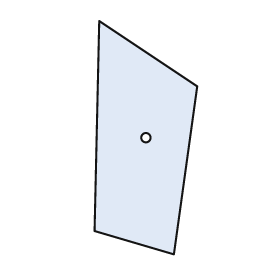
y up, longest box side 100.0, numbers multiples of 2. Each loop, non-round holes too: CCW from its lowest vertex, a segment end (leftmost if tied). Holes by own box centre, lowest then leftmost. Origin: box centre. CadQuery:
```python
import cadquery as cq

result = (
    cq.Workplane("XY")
    .moveTo(12.0, -50.0)
    .lineTo(22.0, 22.0)
    .lineTo(-20.0, 50.0)
    .lineTo(-22.0, -40.0)
    .close()
    .moveTo(0.0, 0.0)
    .circle(2.0)
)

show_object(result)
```